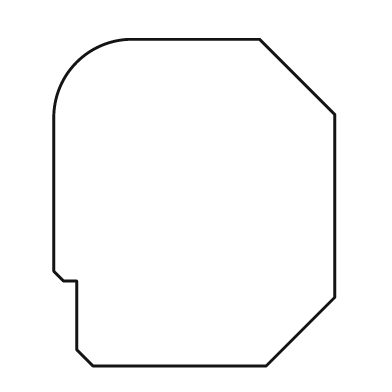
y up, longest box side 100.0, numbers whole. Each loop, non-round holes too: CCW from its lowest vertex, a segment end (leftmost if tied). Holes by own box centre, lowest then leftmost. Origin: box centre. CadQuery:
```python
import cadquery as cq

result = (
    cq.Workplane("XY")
    .moveTo(-31.0, -50.0)
    .lineTo(22.0, -50.0)
    .lineTo(43.0, -29.0)
    .lineTo(43.0, 27.0)
    .lineTo(20.0, 50.0)
    .lineTo(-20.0, 50.0)
    .threePointArc((-36.0, 43.0), (-43.0, 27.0))
    .lineTo(-43.0, -21.0)
    .lineTo(-40.0, -24.0)
    .lineTo(-36.0, -24.0)
    .lineTo(-36.0, -45.0)
    .close()
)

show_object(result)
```